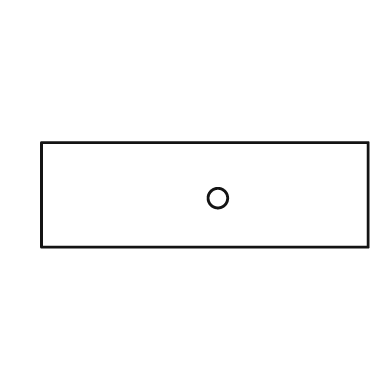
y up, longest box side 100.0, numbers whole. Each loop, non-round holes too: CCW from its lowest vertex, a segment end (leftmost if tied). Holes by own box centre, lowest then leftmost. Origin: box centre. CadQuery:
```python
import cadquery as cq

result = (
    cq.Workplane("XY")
    .moveTo(-50.0, -16.0)
    .lineTo(50.0, -16.0)
    .lineTo(50.0, 16.0)
    .lineTo(-50.0, 16.0)
    .close()
    .moveTo(4.0, -1.0)
    .circle(3.0)
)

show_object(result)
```